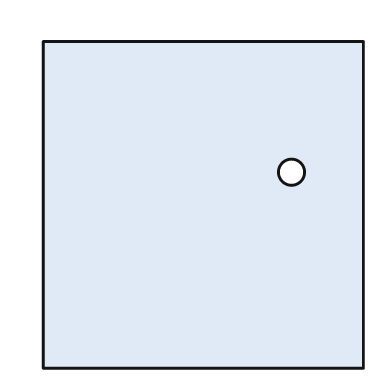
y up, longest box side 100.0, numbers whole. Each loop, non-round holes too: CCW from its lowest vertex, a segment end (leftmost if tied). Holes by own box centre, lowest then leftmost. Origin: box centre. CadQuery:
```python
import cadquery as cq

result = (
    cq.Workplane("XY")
    .moveTo(-49.0, -50.0)
    .lineTo(49.0, -50.0)
    .lineTo(49.0, 50.0)
    .lineTo(-49.0, 50.0)
    .close()
    .moveTo(27.0, 10.0)
    .circle(4.0)
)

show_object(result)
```